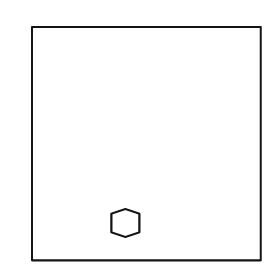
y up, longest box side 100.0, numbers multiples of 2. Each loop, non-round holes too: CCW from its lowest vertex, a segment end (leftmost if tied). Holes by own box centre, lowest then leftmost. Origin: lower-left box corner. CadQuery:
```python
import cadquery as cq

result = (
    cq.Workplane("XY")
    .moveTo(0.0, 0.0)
    .lineTo(98.0, 0.0)
    .lineTo(98.0, 100.0)
    .lineTo(0.0, 100.0)
    .close()
    .moveTo(40.0, 10.0)
    .lineTo(46.0, 12.0)
    .lineTo(46.0, 20.0)
    .lineTo(40.0, 22.0)
    .lineTo(34.0, 20.0)
    .lineTo(34.0, 12.0)
    .close()
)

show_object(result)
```